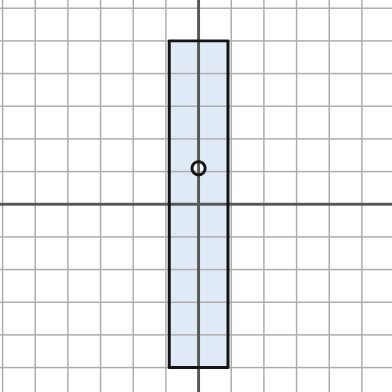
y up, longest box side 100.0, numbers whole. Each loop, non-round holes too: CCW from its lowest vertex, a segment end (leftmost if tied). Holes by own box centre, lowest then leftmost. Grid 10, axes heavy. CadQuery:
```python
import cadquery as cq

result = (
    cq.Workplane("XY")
    .moveTo(-9.0, -50.0)
    .lineTo(9.0, -50.0)
    .lineTo(9.0, 50.0)
    .lineTo(-9.0, 50.0)
    .close()
    .moveTo(0.0, 11.0)
    .circle(2.0)
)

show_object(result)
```